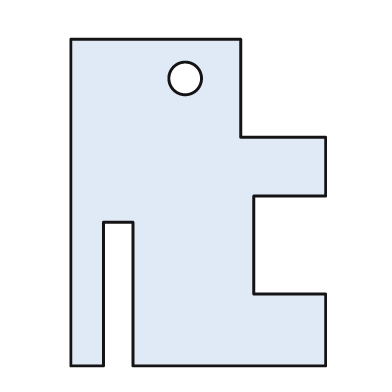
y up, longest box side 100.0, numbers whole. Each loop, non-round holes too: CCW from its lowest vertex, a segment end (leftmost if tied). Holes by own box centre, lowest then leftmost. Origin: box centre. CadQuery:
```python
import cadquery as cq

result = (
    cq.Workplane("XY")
    .moveTo(-39.0, -50.0)
    .lineTo(-29.0, -50.0)
    .lineTo(-29.0, -6.0)
    .lineTo(-20.0, -6.0)
    .lineTo(-20.0, -50.0)
    .lineTo(39.0, -50.0)
    .lineTo(39.0, -28.0)
    .lineTo(17.0, -28.0)
    .lineTo(17.0, 2.0)
    .lineTo(39.0, 2.0)
    .lineTo(39.0, 20.0)
    .lineTo(13.0, 20.0)
    .lineTo(13.0, 50.0)
    .lineTo(-39.0, 50.0)
    .close()
    .moveTo(-4.0, 38.0)
    .circle(5.0)
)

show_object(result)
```